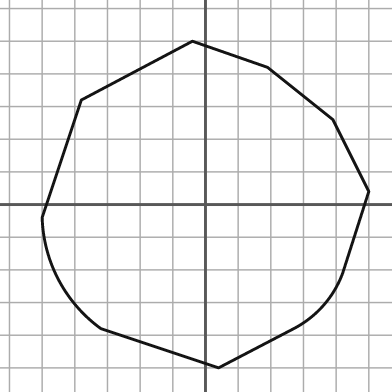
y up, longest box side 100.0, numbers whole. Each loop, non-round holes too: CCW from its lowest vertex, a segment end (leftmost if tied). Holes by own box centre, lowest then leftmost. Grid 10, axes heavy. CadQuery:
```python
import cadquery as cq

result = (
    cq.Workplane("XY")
    .moveTo(4.0, -50.0)
    .lineTo(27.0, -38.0)
    .threePointArc((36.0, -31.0), (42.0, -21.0))
    .lineTo(50.0, 4.0)
    .lineTo(39.0, 26.0)
    .lineTo(19.0, 42.0)
    .lineTo(-4.0, 50.0)
    .lineTo(-38.0, 32.0)
    .lineTo(-50.0, -4.0)
    .threePointArc((-45.0, -23.0), (-32.0, -38.0))
    .close()
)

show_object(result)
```